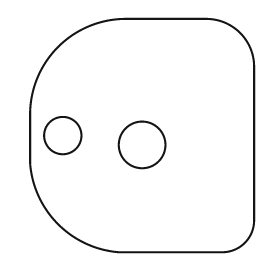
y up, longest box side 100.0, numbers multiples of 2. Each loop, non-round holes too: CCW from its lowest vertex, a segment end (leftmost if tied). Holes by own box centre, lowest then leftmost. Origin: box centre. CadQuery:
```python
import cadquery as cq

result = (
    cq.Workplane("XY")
    .moveTo(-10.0, -50.0)
    .lineTo(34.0, -50.0)
    .threePointArc((44.0, -46.0), (48.0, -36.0))
    .lineTo(48.0, 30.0)
    .threePointArc((42.0, 44.0), (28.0, 50.0))
    .lineTo(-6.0, 50.0)
    .threePointArc((-36.0, 38.0), (-48.0, 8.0))
    .lineTo(-48.0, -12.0)
    .threePointArc((-36.0, -38.0), (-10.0, -50.0))
    .close()
    .moveTo(0.0, -4.0)
    .circle(10.0)
    .moveTo(-34.0, 0.0)
    .circle(8.0)
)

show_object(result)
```